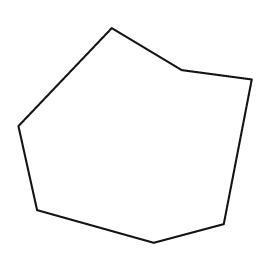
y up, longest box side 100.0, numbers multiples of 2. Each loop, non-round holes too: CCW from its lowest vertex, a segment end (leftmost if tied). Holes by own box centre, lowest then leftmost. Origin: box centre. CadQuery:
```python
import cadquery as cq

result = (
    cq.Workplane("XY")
    .moveTo(8.0, -46.0)
    .lineTo(38.0, -38.0)
    .lineTo(50.0, 24.0)
    .lineTo(20.0, 28.0)
    .lineTo(-10.0, 46.0)
    .lineTo(-50.0, 4.0)
    .lineTo(-42.0, -32.0)
    .close()
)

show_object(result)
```